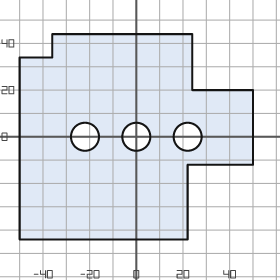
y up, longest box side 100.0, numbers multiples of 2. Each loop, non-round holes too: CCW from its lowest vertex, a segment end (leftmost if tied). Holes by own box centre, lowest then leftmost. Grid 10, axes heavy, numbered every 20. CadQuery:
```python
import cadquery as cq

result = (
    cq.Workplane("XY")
    .moveTo(-50.0, -44.0)
    .lineTo(22.0, -44.0)
    .lineTo(22.0, -12.0)
    .lineTo(50.0, -12.0)
    .lineTo(50.0, 20.0)
    .lineTo(24.0, 20.0)
    .lineTo(24.0, 44.0)
    .lineTo(-36.0, 44.0)
    .lineTo(-36.0, 34.0)
    .lineTo(-50.0, 34.0)
    .close()
    .moveTo(-22.0, 0.0)
    .circle(6.0)
    .moveTo(0.0, 0.0)
    .circle(6.0)
    .moveTo(22.0, 0.0)
    .circle(6.0)
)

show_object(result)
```